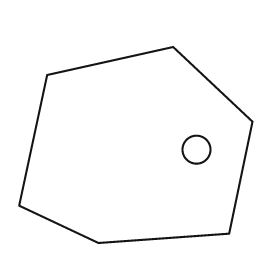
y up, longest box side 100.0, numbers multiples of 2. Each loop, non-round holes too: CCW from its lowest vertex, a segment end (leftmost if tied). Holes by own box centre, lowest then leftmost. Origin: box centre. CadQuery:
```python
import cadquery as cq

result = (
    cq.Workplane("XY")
    .moveTo(-16.0, -42.0)
    .lineTo(40.0, -38.0)
    .lineTo(50.0, 10.0)
    .lineTo(16.0, 42.0)
    .lineTo(-38.0, 30.0)
    .lineTo(-50.0, -26.0)
    .close()
    .moveTo(26.0, -2.0)
    .circle(6.0)
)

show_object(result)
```